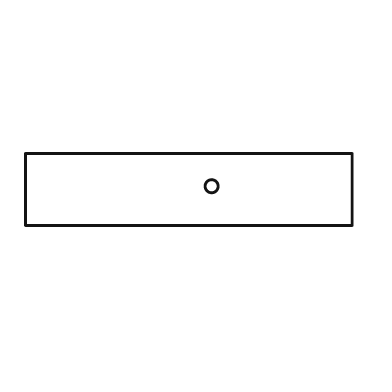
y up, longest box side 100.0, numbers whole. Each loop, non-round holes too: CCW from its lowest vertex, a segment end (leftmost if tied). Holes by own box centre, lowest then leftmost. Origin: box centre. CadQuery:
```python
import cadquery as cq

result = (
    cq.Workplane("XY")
    .moveTo(-50.0, -11.0)
    .lineTo(50.0, -11.0)
    .lineTo(50.0, 11.0)
    .lineTo(-50.0, 11.0)
    .close()
    .moveTo(7.0, 1.0)
    .circle(2.0)
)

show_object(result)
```